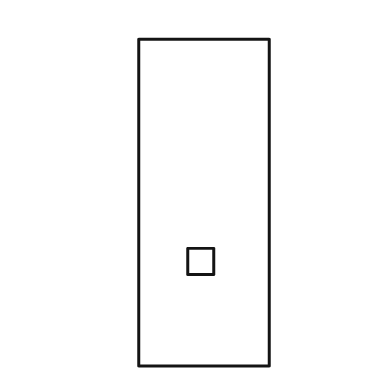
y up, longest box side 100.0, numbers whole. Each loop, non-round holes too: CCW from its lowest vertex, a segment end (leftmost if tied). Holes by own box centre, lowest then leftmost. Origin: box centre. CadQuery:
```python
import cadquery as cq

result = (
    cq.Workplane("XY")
    .moveTo(-20.0, -50.0)
    .lineTo(20.0, -50.0)
    .lineTo(20.0, 50.0)
    .lineTo(-20.0, 50.0)
    .close()
    .moveTo(-5.0, -22.0)
    .lineTo(3.0, -22.0)
    .lineTo(3.0, -14.0)
    .lineTo(-5.0, -14.0)
    .close()
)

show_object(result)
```